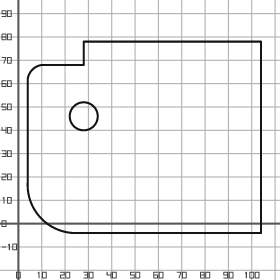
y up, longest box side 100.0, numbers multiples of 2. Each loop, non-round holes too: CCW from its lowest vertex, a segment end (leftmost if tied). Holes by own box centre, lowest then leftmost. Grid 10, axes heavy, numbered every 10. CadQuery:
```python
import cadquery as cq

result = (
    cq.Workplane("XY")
    .moveTo(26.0, -4.0)
    .lineTo(104.0, -4.0)
    .lineTo(104.0, 78.0)
    .lineTo(28.0, 78.0)
    .lineTo(28.0, 68.0)
    .lineTo(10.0, 68.0)
    .threePointArc((6.0, 66.0), (4.0, 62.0))
    .lineTo(4.0, 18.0)
    .threePointArc((10.0, 2.0), (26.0, -4.0))
    .close()
    .moveTo(28.0, 46.0)
    .circle(6.0)
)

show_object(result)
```